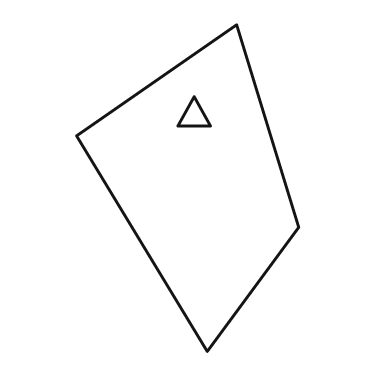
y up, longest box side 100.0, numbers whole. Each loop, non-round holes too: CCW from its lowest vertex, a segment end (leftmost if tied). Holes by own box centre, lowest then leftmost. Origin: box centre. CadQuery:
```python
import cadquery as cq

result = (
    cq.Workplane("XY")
    .moveTo(6.0, -50.0)
    .lineTo(34.0, -12.0)
    .lineTo(15.0, 50.0)
    .lineTo(-34.0, 16.0)
    .close()
    .moveTo(-3.0, 19.0)
    .lineTo(7.0, 19.0)
    .lineTo(2.0, 28.0)
    .close()
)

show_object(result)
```